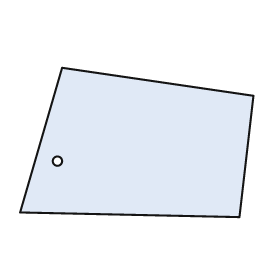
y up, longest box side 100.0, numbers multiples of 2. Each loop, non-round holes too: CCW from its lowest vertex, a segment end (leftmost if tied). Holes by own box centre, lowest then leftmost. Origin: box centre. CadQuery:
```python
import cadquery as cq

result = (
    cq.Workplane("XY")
    .moveTo(44.0, -32.0)
    .lineTo(50.0, 20.0)
    .lineTo(-32.0, 32.0)
    .lineTo(-50.0, -30.0)
    .close()
    .moveTo(-34.0, -8.0)
    .circle(2.0)
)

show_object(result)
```